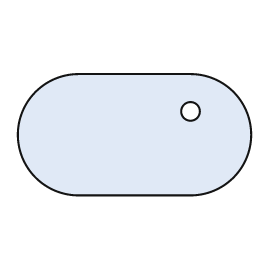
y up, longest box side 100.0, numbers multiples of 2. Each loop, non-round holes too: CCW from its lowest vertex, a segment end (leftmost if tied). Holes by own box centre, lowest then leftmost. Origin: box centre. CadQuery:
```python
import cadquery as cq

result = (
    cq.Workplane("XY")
    .moveTo(-24.0, -26.0)
    .lineTo(24.0, -26.0)
    .threePointArc((50.0, 0.0), (24.0, 26.0))
    .lineTo(-24.0, 26.0)
    .threePointArc((-50.0, 0.0), (-24.0, -26.0))
    .close()
    .moveTo(24.0, 10.0)
    .circle(4.0)
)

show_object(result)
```